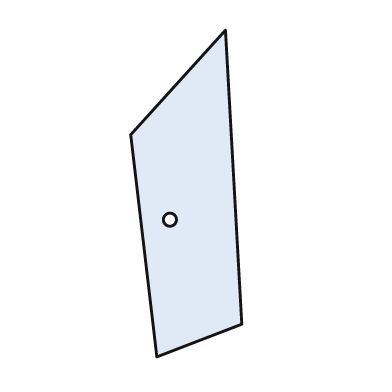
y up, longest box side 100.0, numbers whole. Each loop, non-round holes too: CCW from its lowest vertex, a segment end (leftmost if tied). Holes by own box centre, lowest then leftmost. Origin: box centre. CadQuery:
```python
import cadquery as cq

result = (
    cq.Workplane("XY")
    .moveTo(-9.0, -50.0)
    .lineTo(17.0, -40.0)
    .lineTo(12.0, 50.0)
    .lineTo(-17.0, 18.0)
    .close()
    .moveTo(-5.0, -8.0)
    .circle(2.0)
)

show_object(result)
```